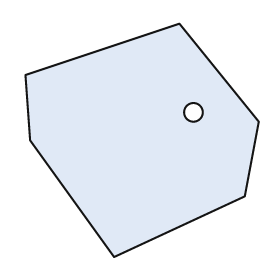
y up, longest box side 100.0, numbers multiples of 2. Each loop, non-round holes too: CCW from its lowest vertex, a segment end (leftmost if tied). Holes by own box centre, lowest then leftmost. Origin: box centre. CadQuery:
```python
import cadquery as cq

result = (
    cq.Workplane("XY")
    .moveTo(-12.0, -50.0)
    .lineTo(44.0, -24.0)
    .lineTo(50.0, 8.0)
    .lineTo(16.0, 50.0)
    .lineTo(-50.0, 28.0)
    .lineTo(-48.0, 0.0)
    .close()
    .moveTo(22.0, 12.0)
    .circle(4.0)
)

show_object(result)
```